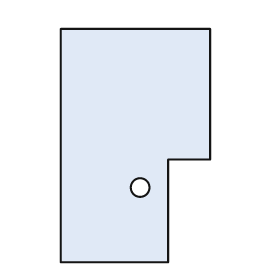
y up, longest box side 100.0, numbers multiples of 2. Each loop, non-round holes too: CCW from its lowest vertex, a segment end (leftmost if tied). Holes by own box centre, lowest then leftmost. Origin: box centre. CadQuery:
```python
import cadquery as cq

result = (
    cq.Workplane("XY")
    .moveTo(-32.0, -50.0)
    .lineTo(14.0, -50.0)
    .lineTo(14.0, -6.0)
    .lineTo(32.0, -6.0)
    .lineTo(32.0, 50.0)
    .lineTo(-32.0, 50.0)
    .close()
    .moveTo(2.0, -18.0)
    .circle(4.0)
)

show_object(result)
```